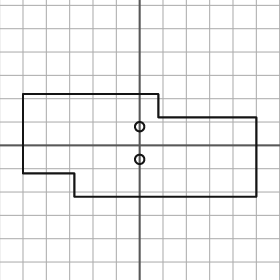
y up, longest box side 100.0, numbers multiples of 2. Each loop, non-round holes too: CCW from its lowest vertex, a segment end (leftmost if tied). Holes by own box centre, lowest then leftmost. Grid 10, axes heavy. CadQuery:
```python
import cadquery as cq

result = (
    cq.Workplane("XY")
    .moveTo(-28.0, -22.0)
    .lineTo(50.0, -22.0)
    .lineTo(50.0, 12.0)
    .lineTo(8.0, 12.0)
    .lineTo(8.0, 22.0)
    .lineTo(-50.0, 22.0)
    .lineTo(-50.0, -12.0)
    .lineTo(-28.0, -12.0)
    .close()
    .moveTo(0.0, -6.0)
    .circle(2.0)
    .moveTo(0.0, 8.0)
    .circle(2.0)
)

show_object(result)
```